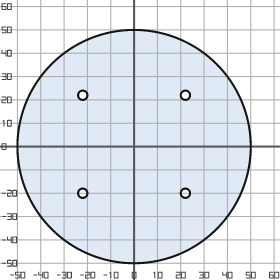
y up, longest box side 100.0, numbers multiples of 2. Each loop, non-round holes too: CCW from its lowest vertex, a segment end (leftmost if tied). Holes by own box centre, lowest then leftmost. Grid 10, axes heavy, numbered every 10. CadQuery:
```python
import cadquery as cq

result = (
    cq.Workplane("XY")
    .moveTo(0.0, 0.0)
    .circle(50.0)
    .moveTo(-22.0, -20.0)
    .circle(2.0)
    .moveTo(22.0, -20.0)
    .circle(2.0)
    .moveTo(-22.0, 22.0)
    .circle(2.0)
    .moveTo(22.0, 22.0)
    .circle(2.0)
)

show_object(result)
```